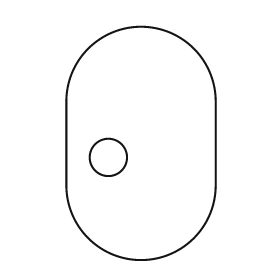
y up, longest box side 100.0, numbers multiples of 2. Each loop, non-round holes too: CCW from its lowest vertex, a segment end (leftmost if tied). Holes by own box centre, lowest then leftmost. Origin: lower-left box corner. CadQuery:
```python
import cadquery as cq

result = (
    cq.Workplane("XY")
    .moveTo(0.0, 32.0)
    .threePointArc((32.0, 0.0), (64.0, 32.0))
    .lineTo(64.0, 68.0)
    .threePointArc((32.0, 100.0), (0.0, 68.0))
    .close()
    .moveTo(18.0, 44.0)
    .circle(8.0)
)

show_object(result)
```